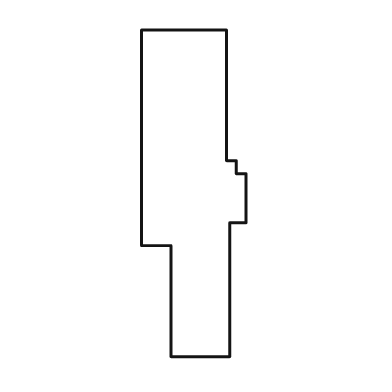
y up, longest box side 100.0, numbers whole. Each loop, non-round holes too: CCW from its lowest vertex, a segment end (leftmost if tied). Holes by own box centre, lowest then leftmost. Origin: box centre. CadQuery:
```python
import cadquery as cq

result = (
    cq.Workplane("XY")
    .moveTo(-7.0, -50.0)
    .lineTo(11.0, -50.0)
    .lineTo(11.0, -9.0)
    .lineTo(16.0, -9.0)
    .lineTo(16.0, 6.0)
    .lineTo(13.0, 6.0)
    .lineTo(13.0, 10.0)
    .lineTo(10.0, 10.0)
    .lineTo(10.0, 50.0)
    .lineTo(-16.0, 50.0)
    .lineTo(-16.0, -16.0)
    .lineTo(-7.0, -16.0)
    .close()
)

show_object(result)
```